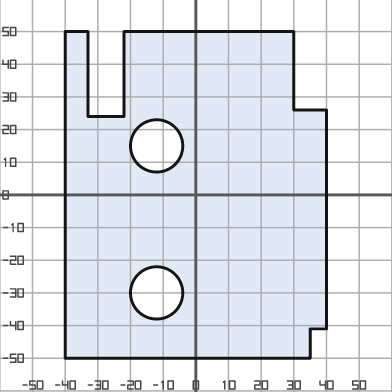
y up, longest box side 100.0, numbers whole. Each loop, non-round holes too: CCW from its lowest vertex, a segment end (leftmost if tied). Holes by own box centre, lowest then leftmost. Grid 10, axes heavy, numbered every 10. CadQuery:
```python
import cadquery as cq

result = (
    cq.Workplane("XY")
    .moveTo(-40.0, -50.0)
    .lineTo(35.0, -50.0)
    .lineTo(35.0, -41.0)
    .lineTo(40.0, -41.0)
    .lineTo(40.0, 26.0)
    .lineTo(30.0, 26.0)
    .lineTo(30.0, 50.0)
    .lineTo(-22.0, 50.0)
    .lineTo(-22.0, 24.0)
    .lineTo(-33.0, 24.0)
    .lineTo(-33.0, 50.0)
    .lineTo(-40.0, 50.0)
    .close()
    .moveTo(-12.0, -30.0)
    .circle(8.0)
    .moveTo(-12.0, 15.0)
    .circle(8.0)
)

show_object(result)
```